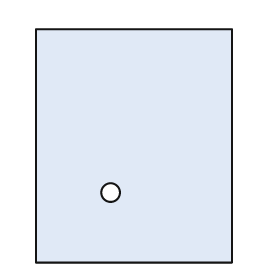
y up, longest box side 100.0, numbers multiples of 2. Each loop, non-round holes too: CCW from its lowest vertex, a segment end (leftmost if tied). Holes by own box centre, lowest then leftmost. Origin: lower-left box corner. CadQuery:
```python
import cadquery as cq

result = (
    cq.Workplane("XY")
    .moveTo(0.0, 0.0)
    .lineTo(84.0, 0.0)
    .lineTo(84.0, 100.0)
    .lineTo(0.0, 100.0)
    .close()
    .moveTo(32.0, 30.0)
    .circle(4.0)
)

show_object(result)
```